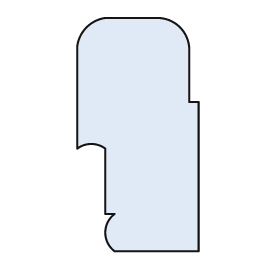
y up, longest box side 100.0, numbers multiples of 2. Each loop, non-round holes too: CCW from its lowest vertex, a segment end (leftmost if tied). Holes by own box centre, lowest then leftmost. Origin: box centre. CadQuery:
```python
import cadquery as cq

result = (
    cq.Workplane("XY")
    .moveTo(-10.0, -50.0)
    .lineTo(26.0, -50.0)
    .lineTo(26.0, 14.0)
    .lineTo(22.0, 14.0)
    .lineTo(22.0, 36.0)
    .threePointArc((18.0, 46.0), (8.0, 50.0))
    .lineTo(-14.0, 50.0)
    .threePointArc((-22.0, 46.0), (-26.0, 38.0))
    .lineTo(-26.0, -6.0)
    .threePointArc((-20.0, -4.0), (-14.0, -6.0))
    .lineTo(-14.0, -34.0)
    .lineTo(-10.0, -34.0)
    .threePointArc((-14.0, -42.0), (-10.0, -50.0))
    .close()
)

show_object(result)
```